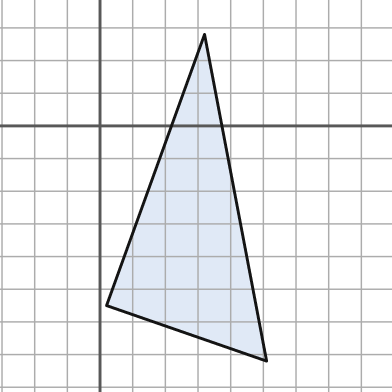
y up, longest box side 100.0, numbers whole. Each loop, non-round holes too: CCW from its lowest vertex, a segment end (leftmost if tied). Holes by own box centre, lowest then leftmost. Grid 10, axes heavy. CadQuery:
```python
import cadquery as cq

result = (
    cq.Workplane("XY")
    .moveTo(51.0, -72.0)
    .lineTo(32.0, 28.0)
    .lineTo(2.0, -55.0)
    .close()
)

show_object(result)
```